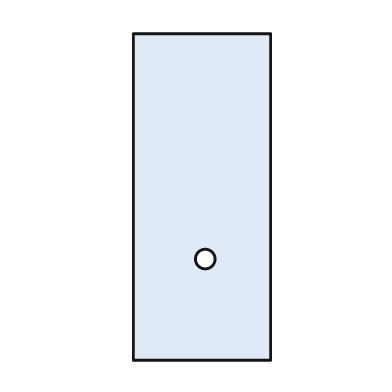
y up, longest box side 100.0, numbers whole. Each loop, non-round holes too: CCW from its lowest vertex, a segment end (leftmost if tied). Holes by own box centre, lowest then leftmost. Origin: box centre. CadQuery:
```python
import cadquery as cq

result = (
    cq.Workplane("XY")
    .moveTo(-21.0, -50.0)
    .lineTo(21.0, -50.0)
    .lineTo(21.0, 50.0)
    .lineTo(-21.0, 50.0)
    .close()
    .moveTo(1.0, -19.0)
    .circle(3.0)
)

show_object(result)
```